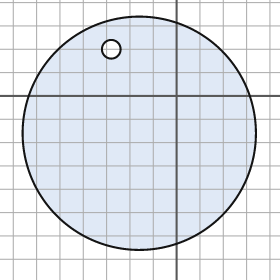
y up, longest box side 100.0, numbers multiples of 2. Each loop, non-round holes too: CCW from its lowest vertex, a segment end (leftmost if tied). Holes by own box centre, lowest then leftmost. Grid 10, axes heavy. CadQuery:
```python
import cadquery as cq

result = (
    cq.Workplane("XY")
    .moveTo(-16.0, -16.0)
    .circle(50.0)
    .moveTo(-28.0, 20.0)
    .circle(4.0)
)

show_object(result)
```